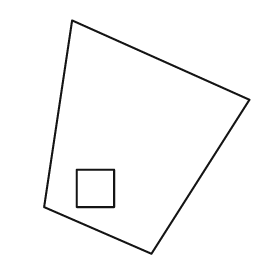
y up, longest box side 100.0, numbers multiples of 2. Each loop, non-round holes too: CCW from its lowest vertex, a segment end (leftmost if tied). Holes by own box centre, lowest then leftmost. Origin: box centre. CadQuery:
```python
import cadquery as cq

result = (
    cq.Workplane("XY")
    .moveTo(2.0, -50.0)
    .lineTo(44.0, 16.0)
    .lineTo(-32.0, 50.0)
    .lineTo(-44.0, -30.0)
    .close()
    .moveTo(-30.0, -30.0)
    .lineTo(-14.0, -30.0)
    .lineTo(-14.0, -14.0)
    .lineTo(-30.0, -14.0)
    .close()
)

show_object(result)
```